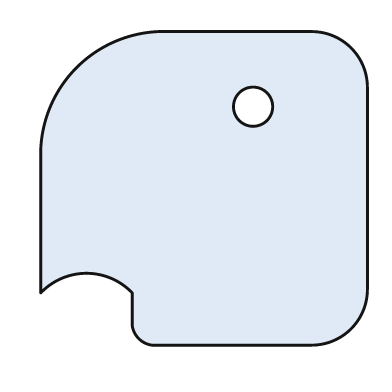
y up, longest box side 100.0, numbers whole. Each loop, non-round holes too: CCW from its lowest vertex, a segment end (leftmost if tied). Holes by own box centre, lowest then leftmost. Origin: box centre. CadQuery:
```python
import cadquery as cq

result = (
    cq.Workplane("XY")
    .moveTo(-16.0, -48.0)
    .lineTo(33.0, -48.0)
    .threePointArc((45.0, -43.0), (50.0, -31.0))
    .lineTo(50.0, 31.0)
    .threePointArc((45.0, 43.0), (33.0, 48.0))
    .lineTo(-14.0, 48.0)
    .threePointArc((-39.0, 37.0), (-50.0, 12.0))
    .lineTo(-50.0, -32.0)
    .threePointArc((-36.0, -26.0), (-22.0, -32.0))
    .lineTo(-22.0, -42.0)
    .threePointArc((-20.0, -46.0), (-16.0, -48.0))
    .close()
    .moveTo(15.0, 25.0)
    .circle(6.0)
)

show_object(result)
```